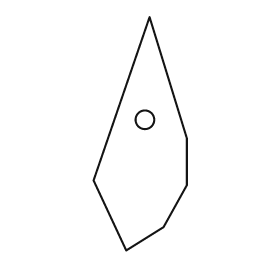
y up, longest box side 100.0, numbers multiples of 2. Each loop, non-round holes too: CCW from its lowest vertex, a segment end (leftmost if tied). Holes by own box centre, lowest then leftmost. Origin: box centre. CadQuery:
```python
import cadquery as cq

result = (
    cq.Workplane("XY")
    .moveTo(-6.0, -50.0)
    .lineTo(10.0, -40.0)
    .lineTo(20.0, -22.0)
    .lineTo(20.0, -2.0)
    .lineTo(4.0, 50.0)
    .lineTo(-20.0, -20.0)
    .close()
    .moveTo(2.0, 6.0)
    .circle(4.0)
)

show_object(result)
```